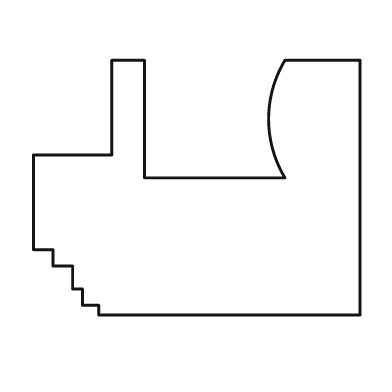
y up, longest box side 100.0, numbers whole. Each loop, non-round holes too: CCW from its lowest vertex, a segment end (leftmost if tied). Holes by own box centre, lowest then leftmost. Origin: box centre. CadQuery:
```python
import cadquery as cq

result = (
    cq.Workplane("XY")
    .moveTo(-30.0, -39.0)
    .lineTo(50.0, -39.0)
    .lineTo(50.0, 39.0)
    .lineTo(27.0, 39.0)
    .threePointArc((22.0, 21.0), (27.0, 3.0))
    .lineTo(-16.0, 3.0)
    .lineTo(-16.0, 39.0)
    .lineTo(-26.0, 39.0)
    .lineTo(-26.0, 10.0)
    .lineTo(-50.0, 10.0)
    .lineTo(-50.0, -19.0)
    .lineTo(-44.0, -19.0)
    .lineTo(-44.0, -24.0)
    .lineTo(-38.0, -24.0)
    .lineTo(-38.0, -31.0)
    .lineTo(-35.0, -31.0)
    .lineTo(-35.0, -36.0)
    .lineTo(-30.0, -36.0)
    .close()
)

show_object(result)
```